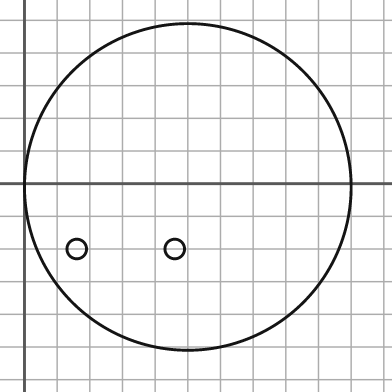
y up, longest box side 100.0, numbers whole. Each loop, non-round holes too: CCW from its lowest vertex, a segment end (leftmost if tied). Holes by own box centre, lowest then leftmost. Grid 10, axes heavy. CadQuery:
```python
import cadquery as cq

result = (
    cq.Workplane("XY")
    .moveTo(50.0, -1.0)
    .circle(50.0)
    .moveTo(16.0, -20.0)
    .circle(3.0)
    .moveTo(46.0, -20.0)
    .circle(3.0)
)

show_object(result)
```